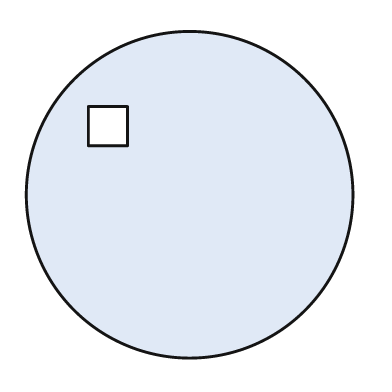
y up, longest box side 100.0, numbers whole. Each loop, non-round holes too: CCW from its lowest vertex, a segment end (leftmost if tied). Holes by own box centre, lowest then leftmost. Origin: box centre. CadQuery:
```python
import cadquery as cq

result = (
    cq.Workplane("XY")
    .moveTo(0.0, 0.0)
    .circle(50.0)
    .moveTo(-31.0, 15.0)
    .lineTo(-19.0, 15.0)
    .lineTo(-19.0, 27.0)
    .lineTo(-31.0, 27.0)
    .close()
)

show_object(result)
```